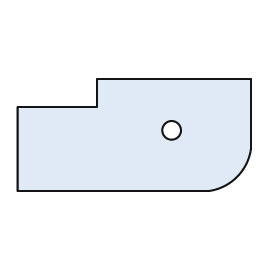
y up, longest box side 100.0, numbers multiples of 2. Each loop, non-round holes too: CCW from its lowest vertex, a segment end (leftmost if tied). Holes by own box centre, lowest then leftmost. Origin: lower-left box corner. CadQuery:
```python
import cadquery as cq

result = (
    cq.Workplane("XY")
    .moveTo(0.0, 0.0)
    .lineTo(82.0, 0.0)
    .threePointArc((94.0, 6.0), (100.0, 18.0))
    .lineTo(100.0, 48.0)
    .lineTo(34.0, 48.0)
    .lineTo(34.0, 36.0)
    .lineTo(0.0, 36.0)
    .close()
    .moveTo(66.0, 26.0)
    .circle(4.0)
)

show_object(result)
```